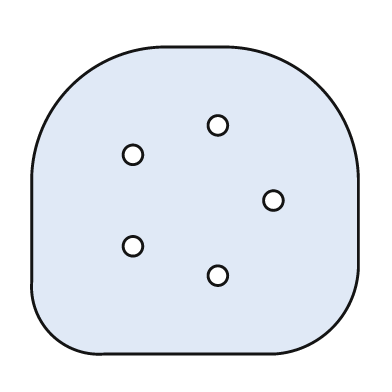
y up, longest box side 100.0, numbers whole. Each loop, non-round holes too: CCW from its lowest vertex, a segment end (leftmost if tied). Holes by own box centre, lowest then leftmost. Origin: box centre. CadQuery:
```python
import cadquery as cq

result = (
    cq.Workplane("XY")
    .moveTo(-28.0, -47.0)
    .lineTo(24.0, -47.0)
    .threePointArc((42.0, -39.0), (50.0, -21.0))
    .lineTo(50.0, 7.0)
    .threePointArc((38.0, 35.0), (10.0, 47.0))
    .lineTo(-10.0, 47.0)
    .threePointArc((-38.0, 35.0), (-50.0, 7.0))
    .lineTo(-50.0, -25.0)
    .threePointArc((-44.0, -41.0), (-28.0, -47.0))
    .close()
    .moveTo(7.0, -23.0)
    .circle(3.0)
    .moveTo(-19.0, -14.0)
    .circle(3.0)
    .moveTo(24.0, 0.0)
    .circle(3.0)
    .moveTo(-19.0, 14.0)
    .circle(3.0)
    .moveTo(7.0, 23.0)
    .circle(3.0)
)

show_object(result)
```